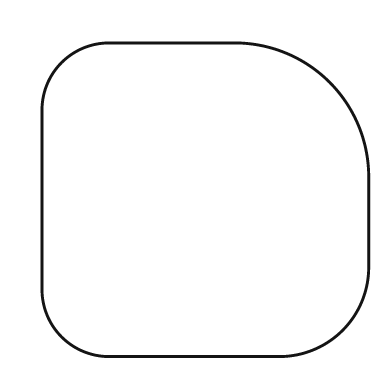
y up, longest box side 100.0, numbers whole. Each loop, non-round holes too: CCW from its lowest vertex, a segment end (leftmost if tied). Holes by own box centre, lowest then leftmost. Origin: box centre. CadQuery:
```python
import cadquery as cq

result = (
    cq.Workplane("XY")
    .moveTo(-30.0, -48.0)
    .lineTo(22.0, -48.0)
    .threePointArc((42.0, -40.0), (50.0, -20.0))
    .lineTo(50.0, 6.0)
    .threePointArc((38.0, 36.0), (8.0, 48.0))
    .lineTo(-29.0, 48.0)
    .threePointArc((-44.0, 42.0), (-50.0, 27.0))
    .lineTo(-50.0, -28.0)
    .threePointArc((-44.0, -42.0), (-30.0, -48.0))
    .close()
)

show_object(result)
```